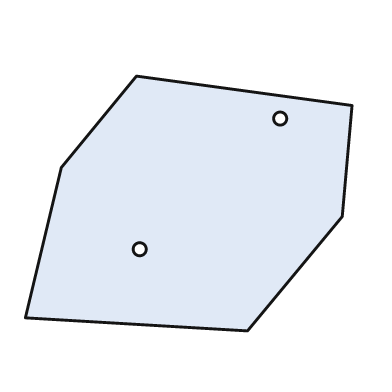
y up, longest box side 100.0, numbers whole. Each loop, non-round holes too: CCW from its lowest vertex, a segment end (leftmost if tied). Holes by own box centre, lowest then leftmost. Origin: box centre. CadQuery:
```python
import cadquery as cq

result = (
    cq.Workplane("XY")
    .moveTo(18.0, -39.0)
    .lineTo(47.0, -4.0)
    .lineTo(50.0, 30.0)
    .lineTo(-16.0, 39.0)
    .lineTo(-39.0, 11.0)
    .lineTo(-50.0, -35.0)
    .close()
    .moveTo(-15.0, -14.0)
    .circle(2.0)
    .moveTo(28.0, 26.0)
    .circle(2.0)
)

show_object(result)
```